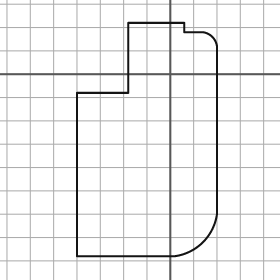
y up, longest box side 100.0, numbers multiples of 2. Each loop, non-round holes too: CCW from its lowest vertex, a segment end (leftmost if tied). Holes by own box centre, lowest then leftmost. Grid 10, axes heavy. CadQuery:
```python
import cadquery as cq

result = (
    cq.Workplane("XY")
    .moveTo(-40.0, -78.0)
    .lineTo(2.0, -78.0)
    .threePointArc((14.0, -72.0), (20.0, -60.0))
    .lineTo(20.0, 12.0)
    .threePointArc((18.0, 16.0), (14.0, 18.0))
    .lineTo(6.0, 18.0)
    .lineTo(6.0, 22.0)
    .lineTo(-18.0, 22.0)
    .lineTo(-18.0, -8.0)
    .lineTo(-40.0, -8.0)
    .close()
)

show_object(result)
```